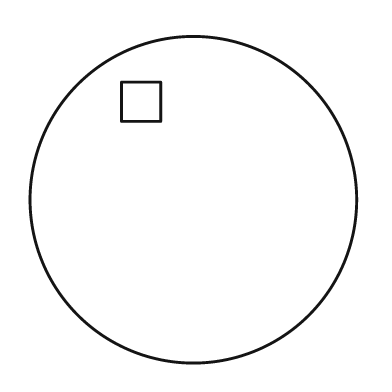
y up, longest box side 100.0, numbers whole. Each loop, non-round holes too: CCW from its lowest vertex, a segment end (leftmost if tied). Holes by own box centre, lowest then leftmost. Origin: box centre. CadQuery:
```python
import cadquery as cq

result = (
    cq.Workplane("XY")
    .moveTo(0.0, 0.0)
    .circle(50.0)
    .moveTo(-22.0, 24.0)
    .lineTo(-10.0, 24.0)
    .lineTo(-10.0, 36.0)
    .lineTo(-22.0, 36.0)
    .close()
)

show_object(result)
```